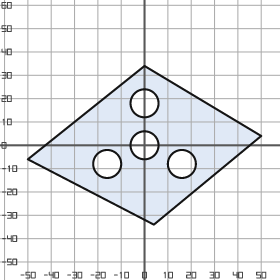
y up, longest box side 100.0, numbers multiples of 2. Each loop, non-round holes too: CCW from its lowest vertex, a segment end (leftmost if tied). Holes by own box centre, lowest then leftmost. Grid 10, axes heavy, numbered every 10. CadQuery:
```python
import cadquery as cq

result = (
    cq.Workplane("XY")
    .moveTo(4.0, -34.0)
    .lineTo(50.0, 4.0)
    .lineTo(0.0, 34.0)
    .lineTo(-50.0, -6.0)
    .close()
    .moveTo(-16.0, -8.0)
    .circle(6.0)
    .moveTo(16.0, -8.0)
    .circle(6.0)
    .moveTo(0.0, 0.0)
    .circle(6.0)
    .moveTo(0.0, 18.0)
    .circle(6.0)
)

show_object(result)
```